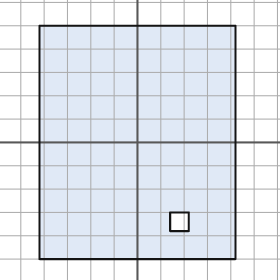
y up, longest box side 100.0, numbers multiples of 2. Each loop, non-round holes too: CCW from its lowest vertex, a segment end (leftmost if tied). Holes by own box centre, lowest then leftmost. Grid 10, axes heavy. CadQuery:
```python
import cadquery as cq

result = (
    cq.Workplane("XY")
    .moveTo(-42.0, -50.0)
    .lineTo(42.0, -50.0)
    .lineTo(42.0, 50.0)
    .lineTo(-42.0, 50.0)
    .close()
    .moveTo(14.0, -38.0)
    .lineTo(22.0, -38.0)
    .lineTo(22.0, -30.0)
    .lineTo(14.0, -30.0)
    .close()
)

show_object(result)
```